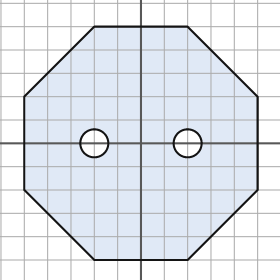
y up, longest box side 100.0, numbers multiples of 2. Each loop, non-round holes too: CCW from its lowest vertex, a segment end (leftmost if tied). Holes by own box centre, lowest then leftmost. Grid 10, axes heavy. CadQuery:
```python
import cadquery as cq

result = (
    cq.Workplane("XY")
    .moveTo(-20.0, -50.0)
    .lineTo(20.0, -50.0)
    .lineTo(50.0, -20.0)
    .lineTo(50.0, 20.0)
    .lineTo(20.0, 50.0)
    .lineTo(-20.0, 50.0)
    .lineTo(-50.0, 20.0)
    .lineTo(-50.0, -20.0)
    .close()
    .moveTo(-20.0, 0.0)
    .circle(6.0)
    .moveTo(20.0, 0.0)
    .circle(6.0)
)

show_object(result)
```